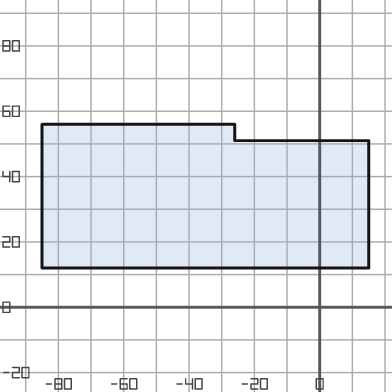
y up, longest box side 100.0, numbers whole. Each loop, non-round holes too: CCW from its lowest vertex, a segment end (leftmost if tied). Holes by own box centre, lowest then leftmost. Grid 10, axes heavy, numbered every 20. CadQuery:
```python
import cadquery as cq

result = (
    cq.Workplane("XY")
    .moveTo(-85.0, 12.0)
    .lineTo(15.0, 12.0)
    .lineTo(15.0, 51.0)
    .lineTo(-26.0, 51.0)
    .lineTo(-26.0, 56.0)
    .lineTo(-85.0, 56.0)
    .close()
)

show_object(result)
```